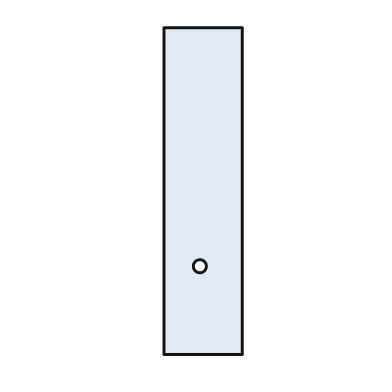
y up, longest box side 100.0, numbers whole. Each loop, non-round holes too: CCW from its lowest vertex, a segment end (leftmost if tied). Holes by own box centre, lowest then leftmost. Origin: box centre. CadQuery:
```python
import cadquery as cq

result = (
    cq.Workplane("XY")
    .moveTo(-12.0, -50.0)
    .lineTo(12.0, -50.0)
    .lineTo(12.0, 50.0)
    .lineTo(-12.0, 50.0)
    .close()
    .moveTo(-1.0, -23.0)
    .circle(2.0)
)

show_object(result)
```